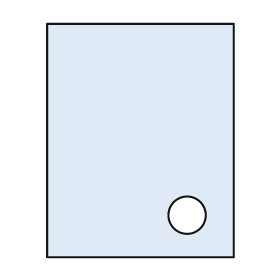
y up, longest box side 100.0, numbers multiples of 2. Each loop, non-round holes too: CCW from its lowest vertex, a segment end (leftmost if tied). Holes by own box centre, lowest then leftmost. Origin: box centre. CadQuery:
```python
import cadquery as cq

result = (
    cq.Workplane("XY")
    .moveTo(-40.0, -50.0)
    .lineTo(40.0, -50.0)
    .lineTo(40.0, 50.0)
    .lineTo(-40.0, 50.0)
    .close()
    .moveTo(20.0, -32.0)
    .circle(8.0)
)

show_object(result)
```